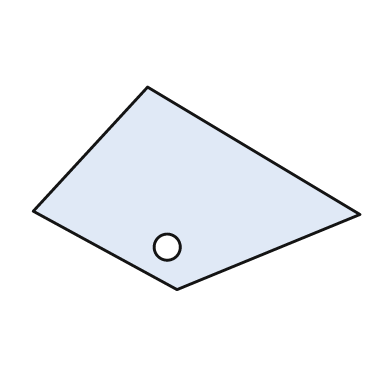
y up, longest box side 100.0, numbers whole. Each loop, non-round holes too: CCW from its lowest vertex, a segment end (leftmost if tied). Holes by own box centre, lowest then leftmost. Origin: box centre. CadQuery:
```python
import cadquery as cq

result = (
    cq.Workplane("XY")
    .moveTo(-6.0, -31.0)
    .lineTo(50.0, -8.0)
    .lineTo(-15.0, 31.0)
    .lineTo(-50.0, -7.0)
    .close()
    .moveTo(-9.0, -18.0)
    .circle(4.0)
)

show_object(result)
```